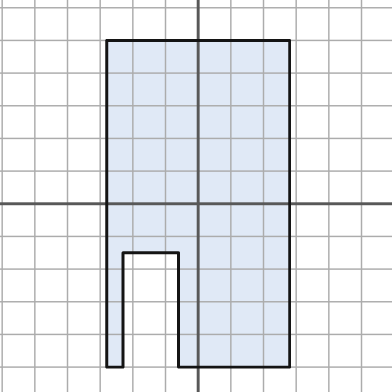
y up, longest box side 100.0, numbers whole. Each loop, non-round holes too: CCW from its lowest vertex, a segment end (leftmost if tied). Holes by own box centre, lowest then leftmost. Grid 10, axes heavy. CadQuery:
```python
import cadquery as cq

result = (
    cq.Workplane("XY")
    .moveTo(-28.0, -50.0)
    .lineTo(-23.0, -50.0)
    .lineTo(-23.0, -15.0)
    .lineTo(-6.0, -15.0)
    .lineTo(-6.0, -50.0)
    .lineTo(28.0, -50.0)
    .lineTo(28.0, 50.0)
    .lineTo(-28.0, 50.0)
    .close()
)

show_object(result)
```